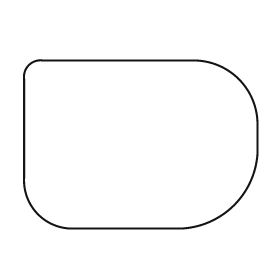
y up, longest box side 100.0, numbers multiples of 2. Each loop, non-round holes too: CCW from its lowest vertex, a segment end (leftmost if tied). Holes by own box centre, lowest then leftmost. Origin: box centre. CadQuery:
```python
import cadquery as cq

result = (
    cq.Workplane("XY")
    .moveTo(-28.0, -36.0)
    .lineTo(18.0, -36.0)
    .threePointArc((40.0, -26.0), (50.0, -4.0))
    .lineTo(50.0, 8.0)
    .threePointArc((42.0, 28.0), (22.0, 36.0))
    .lineTo(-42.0, 36.0)
    .threePointArc((-48.0, 34.0), (-50.0, 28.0))
    .lineTo(-50.0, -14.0)
    .threePointArc((-44.0, -30.0), (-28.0, -36.0))
    .close()
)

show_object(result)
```